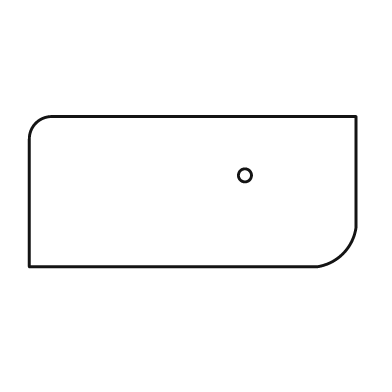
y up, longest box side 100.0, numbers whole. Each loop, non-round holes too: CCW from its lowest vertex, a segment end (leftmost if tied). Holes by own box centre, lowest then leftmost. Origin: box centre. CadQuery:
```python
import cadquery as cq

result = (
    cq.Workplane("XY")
    .moveTo(-50.0, -23.0)
    .lineTo(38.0, -23.0)
    .threePointArc((46.0, -19.0), (50.0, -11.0))
    .lineTo(50.0, 23.0)
    .lineTo(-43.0, 23.0)
    .threePointArc((-48.0, 21.0), (-50.0, 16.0))
    .close()
    .moveTo(16.0, 5.0)
    .circle(2.0)
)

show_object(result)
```